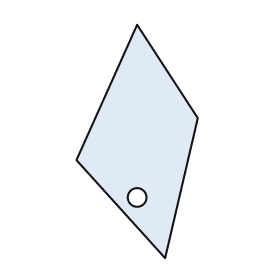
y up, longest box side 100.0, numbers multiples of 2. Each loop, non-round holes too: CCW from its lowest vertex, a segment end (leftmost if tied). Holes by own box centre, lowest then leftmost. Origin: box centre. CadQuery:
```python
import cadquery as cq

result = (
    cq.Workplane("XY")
    .moveTo(12.0, -50.0)
    .lineTo(26.0, 10.0)
    .lineTo(0.0, 50.0)
    .lineTo(-26.0, -8.0)
    .close()
    .moveTo(0.0, -24.0)
    .circle(4.0)
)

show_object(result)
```